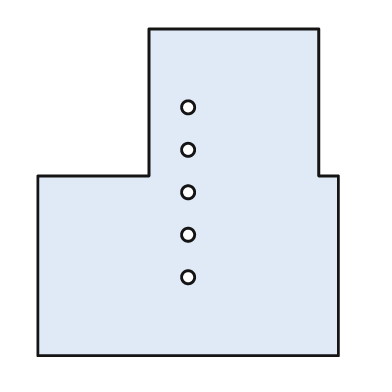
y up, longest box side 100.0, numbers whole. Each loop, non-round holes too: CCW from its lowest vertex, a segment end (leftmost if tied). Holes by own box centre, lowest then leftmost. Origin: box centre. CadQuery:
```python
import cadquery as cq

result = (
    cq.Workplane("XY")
    .moveTo(-46.0, -50.0)
    .lineTo(46.0, -50.0)
    .lineTo(46.0, 5.0)
    .lineTo(40.0, 5.0)
    .lineTo(40.0, 50.0)
    .lineTo(-12.0, 50.0)
    .lineTo(-12.0, 5.0)
    .lineTo(-46.0, 5.0)
    .close()
    .moveTo(0.0, -26.0)
    .circle(2.0)
    .moveTo(0.0, -13.0)
    .circle(2.0)
    .moveTo(0.0, 0.0)
    .circle(2.0)
    .moveTo(0.0, 13.0)
    .circle(2.0)
    .moveTo(0.0, 26.0)
    .circle(2.0)
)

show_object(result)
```